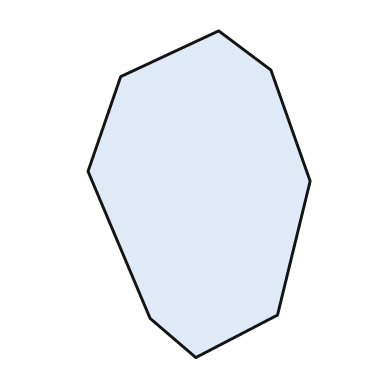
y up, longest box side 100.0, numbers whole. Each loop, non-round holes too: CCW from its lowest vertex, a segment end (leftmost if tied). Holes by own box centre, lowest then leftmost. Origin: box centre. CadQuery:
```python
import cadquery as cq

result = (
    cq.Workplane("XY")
    .moveTo(-1.0, -50.0)
    .lineTo(24.0, -37.0)
    .lineTo(34.0, 4.0)
    .lineTo(22.0, 38.0)
    .lineTo(6.0, 50.0)
    .lineTo(-24.0, 36.0)
    .lineTo(-34.0, 7.0)
    .lineTo(-15.0, -38.0)
    .close()
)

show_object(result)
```